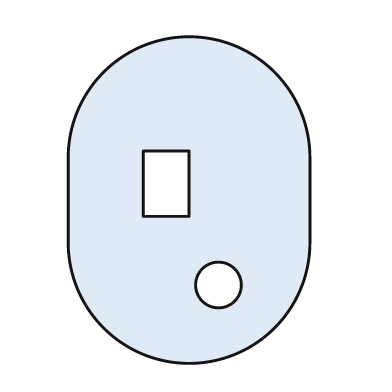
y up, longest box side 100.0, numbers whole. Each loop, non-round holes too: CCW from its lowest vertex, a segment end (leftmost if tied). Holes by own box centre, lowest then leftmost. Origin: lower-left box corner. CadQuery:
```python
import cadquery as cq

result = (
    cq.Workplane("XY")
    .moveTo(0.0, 37.0)
    .threePointArc((37.0, 0.0), (74.0, 37.0))
    .lineTo(74.0, 63.0)
    .threePointArc((37.0, 100.0), (0.0, 63.0))
    .close()
    .moveTo(46.0, 24.0)
    .circle(7.0)
    .moveTo(23.0, 45.0)
    .lineTo(37.0, 45.0)
    .lineTo(37.0, 65.0)
    .lineTo(23.0, 65.0)
    .close()
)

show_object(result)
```